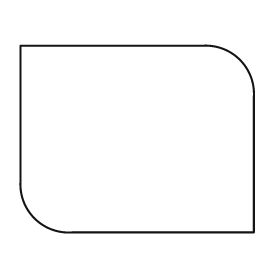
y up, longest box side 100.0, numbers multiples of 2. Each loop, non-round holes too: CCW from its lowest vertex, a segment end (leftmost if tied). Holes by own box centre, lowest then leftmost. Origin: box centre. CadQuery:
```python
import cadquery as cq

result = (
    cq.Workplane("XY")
    .moveTo(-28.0, -40.0)
    .lineTo(50.0, -40.0)
    .lineTo(50.0, 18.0)
    .threePointArc((44.0, 34.0), (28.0, 40.0))
    .lineTo(-50.0, 40.0)
    .lineTo(-50.0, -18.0)
    .threePointArc((-44.0, -34.0), (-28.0, -40.0))
    .close()
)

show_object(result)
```